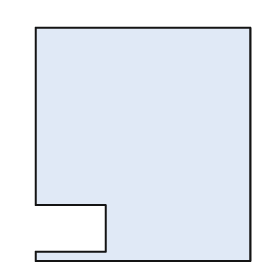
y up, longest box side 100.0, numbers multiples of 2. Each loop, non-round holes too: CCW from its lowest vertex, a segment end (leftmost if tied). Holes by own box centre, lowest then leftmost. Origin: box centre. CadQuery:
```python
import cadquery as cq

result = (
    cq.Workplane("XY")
    .moveTo(-46.0, -50.0)
    .lineTo(46.0, -50.0)
    .lineTo(46.0, 50.0)
    .lineTo(-46.0, 50.0)
    .lineTo(-46.0, -26.0)
    .lineTo(-16.0, -26.0)
    .lineTo(-16.0, -46.0)
    .lineTo(-46.0, -46.0)
    .close()
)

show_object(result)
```